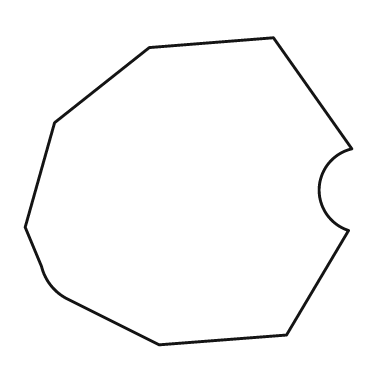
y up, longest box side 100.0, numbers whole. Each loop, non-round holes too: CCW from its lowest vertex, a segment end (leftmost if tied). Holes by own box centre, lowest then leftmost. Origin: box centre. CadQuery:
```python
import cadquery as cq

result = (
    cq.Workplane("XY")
    .moveTo(-9.0, -47.0)
    .lineTo(30.0, -44.0)
    .lineTo(49.0, -12.0)
    .threePointArc((40.0, 1.0), (50.0, 13.0))
    .lineTo(26.0, 47.0)
    .lineTo(-12.0, 44.0)
    .lineTo(-41.0, 21.0)
    .lineTo(-50.0, -11.0)
    .lineTo(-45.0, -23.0)
    .threePointArc((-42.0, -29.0), (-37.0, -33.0))
    .close()
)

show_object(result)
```